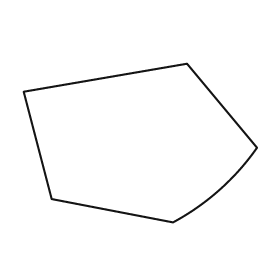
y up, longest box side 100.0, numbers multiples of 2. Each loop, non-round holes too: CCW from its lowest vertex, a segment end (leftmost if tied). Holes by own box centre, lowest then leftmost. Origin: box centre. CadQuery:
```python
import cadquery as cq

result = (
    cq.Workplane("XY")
    .moveTo(14.0, -34.0)
    .threePointArc((34.0, -20.0), (50.0, -2.0))
    .lineTo(20.0, 34.0)
    .lineTo(-50.0, 22.0)
    .lineTo(-38.0, -24.0)
    .close()
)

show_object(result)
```